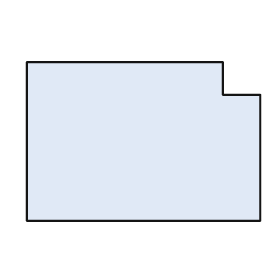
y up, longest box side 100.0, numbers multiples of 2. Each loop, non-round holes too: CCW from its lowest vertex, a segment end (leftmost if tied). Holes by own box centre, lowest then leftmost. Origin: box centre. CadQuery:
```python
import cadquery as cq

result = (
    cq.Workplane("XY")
    .moveTo(-50.0, -34.0)
    .lineTo(50.0, -34.0)
    .lineTo(50.0, 20.0)
    .lineTo(34.0, 20.0)
    .lineTo(34.0, 34.0)
    .lineTo(-50.0, 34.0)
    .close()
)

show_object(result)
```